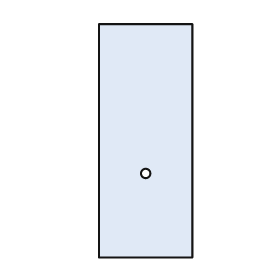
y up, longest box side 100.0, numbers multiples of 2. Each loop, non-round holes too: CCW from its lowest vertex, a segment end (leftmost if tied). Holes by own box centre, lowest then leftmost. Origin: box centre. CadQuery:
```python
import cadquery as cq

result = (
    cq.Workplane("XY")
    .moveTo(-20.0, -50.0)
    .lineTo(20.0, -50.0)
    .lineTo(20.0, 50.0)
    .lineTo(-20.0, 50.0)
    .close()
    .moveTo(0.0, -14.0)
    .circle(2.0)
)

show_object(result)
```